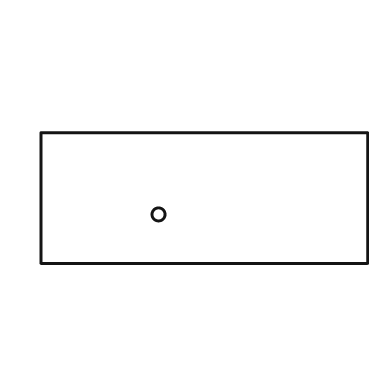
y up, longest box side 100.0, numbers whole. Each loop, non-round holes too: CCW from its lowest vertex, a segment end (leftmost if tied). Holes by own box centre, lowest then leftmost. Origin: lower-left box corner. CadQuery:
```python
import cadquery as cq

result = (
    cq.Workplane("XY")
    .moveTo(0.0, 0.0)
    .lineTo(100.0, 0.0)
    .lineTo(100.0, 40.0)
    .lineTo(0.0, 40.0)
    .close()
    .moveTo(36.0, 15.0)
    .circle(2.0)
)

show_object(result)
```